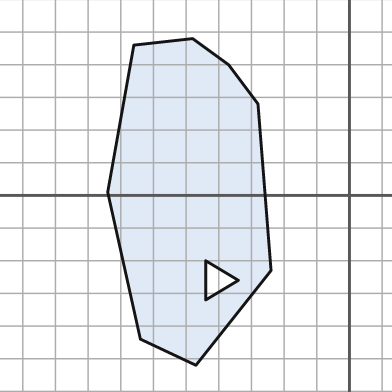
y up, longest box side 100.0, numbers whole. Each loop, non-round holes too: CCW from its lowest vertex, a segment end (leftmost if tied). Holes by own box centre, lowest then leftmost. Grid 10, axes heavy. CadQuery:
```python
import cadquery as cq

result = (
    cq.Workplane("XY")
    .moveTo(-47.0, -52.0)
    .lineTo(-24.0, -23.0)
    .lineTo(-28.0, 28.0)
    .lineTo(-37.0, 40.0)
    .lineTo(-48.0, 48.0)
    .lineTo(-66.0, 46.0)
    .lineTo(-74.0, 1.0)
    .lineTo(-64.0, -44.0)
    .close()
    .moveTo(-44.0, -32.0)
    .lineTo(-34.0, -26.0)
    .lineTo(-44.0, -20.0)
    .close()
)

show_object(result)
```